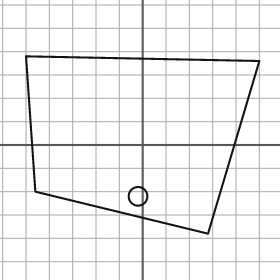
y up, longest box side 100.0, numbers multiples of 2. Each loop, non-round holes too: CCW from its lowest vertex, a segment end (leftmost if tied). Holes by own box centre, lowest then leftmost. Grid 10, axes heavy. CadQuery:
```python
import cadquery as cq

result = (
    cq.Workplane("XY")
    .moveTo(28.0, -38.0)
    .lineTo(50.0, 36.0)
    .lineTo(-50.0, 38.0)
    .lineTo(-46.0, -20.0)
    .close()
    .moveTo(-2.0, -22.0)
    .circle(4.0)
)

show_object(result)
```